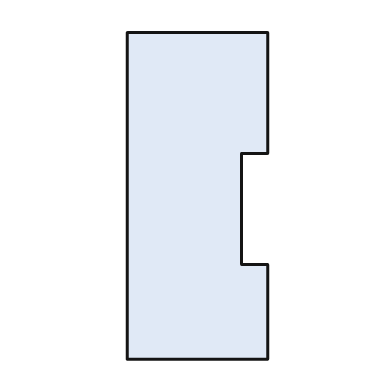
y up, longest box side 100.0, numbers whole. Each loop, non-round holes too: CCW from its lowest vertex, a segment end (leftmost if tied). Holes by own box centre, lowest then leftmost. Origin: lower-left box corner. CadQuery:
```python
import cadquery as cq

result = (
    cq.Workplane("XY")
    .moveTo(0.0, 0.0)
    .lineTo(43.0, 0.0)
    .lineTo(43.0, 29.0)
    .lineTo(35.0, 29.0)
    .lineTo(35.0, 63.0)
    .lineTo(43.0, 63.0)
    .lineTo(43.0, 100.0)
    .lineTo(0.0, 100.0)
    .close()
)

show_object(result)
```